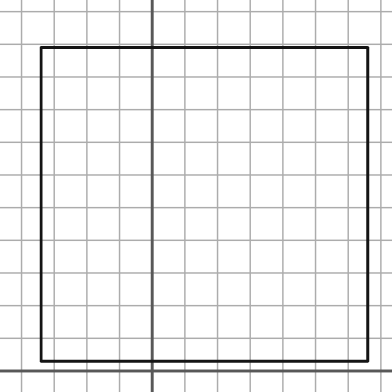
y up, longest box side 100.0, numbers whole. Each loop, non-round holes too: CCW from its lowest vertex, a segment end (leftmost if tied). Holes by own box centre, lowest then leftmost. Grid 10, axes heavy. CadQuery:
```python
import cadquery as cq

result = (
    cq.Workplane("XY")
    .moveTo(-34.0, 3.0)
    .lineTo(66.0, 3.0)
    .lineTo(66.0, 99.0)
    .lineTo(-34.0, 99.0)
    .close()
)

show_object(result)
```